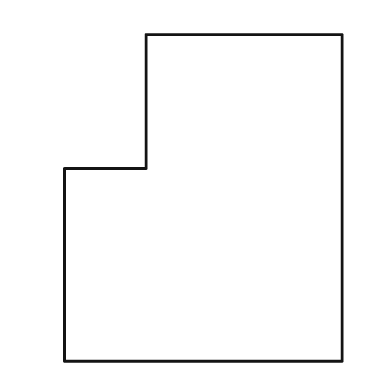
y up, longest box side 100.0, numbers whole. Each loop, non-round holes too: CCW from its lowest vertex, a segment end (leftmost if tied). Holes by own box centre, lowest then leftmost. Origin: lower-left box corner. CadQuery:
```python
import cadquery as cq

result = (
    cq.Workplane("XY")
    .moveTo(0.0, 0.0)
    .lineTo(85.0, 0.0)
    .lineTo(85.0, 100.0)
    .lineTo(25.0, 100.0)
    .lineTo(25.0, 59.0)
    .lineTo(0.0, 59.0)
    .close()
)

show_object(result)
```